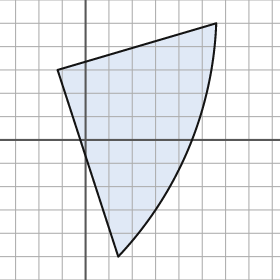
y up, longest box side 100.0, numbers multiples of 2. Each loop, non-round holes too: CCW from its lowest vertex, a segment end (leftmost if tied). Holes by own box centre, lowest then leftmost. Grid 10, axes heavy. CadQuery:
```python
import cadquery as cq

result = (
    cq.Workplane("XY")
    .moveTo(14.0, -50.0)
    .threePointArc((44.0, -4.0), (56.0, 50.0))
    .lineTo(-12.0, 30.0)
    .close()
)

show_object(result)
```